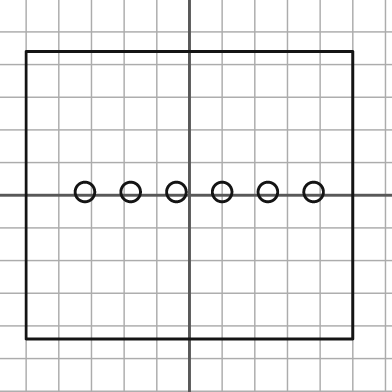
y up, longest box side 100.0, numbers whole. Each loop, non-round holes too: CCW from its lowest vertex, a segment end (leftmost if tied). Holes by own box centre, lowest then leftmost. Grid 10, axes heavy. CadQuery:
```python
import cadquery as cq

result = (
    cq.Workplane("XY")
    .moveTo(-50.0, -44.0)
    .lineTo(50.0, -44.0)
    .lineTo(50.0, 44.0)
    .lineTo(-50.0, 44.0)
    .close()
    .moveTo(-32.0, 1.0)
    .circle(3.0)
    .moveTo(-18.0, 1.0)
    .circle(3.0)
    .moveTo(-4.0, 1.0)
    .circle(3.0)
    .moveTo(10.0, 1.0)
    .circle(3.0)
    .moveTo(24.0, 1.0)
    .circle(3.0)
    .moveTo(38.0, 1.0)
    .circle(3.0)
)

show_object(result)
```